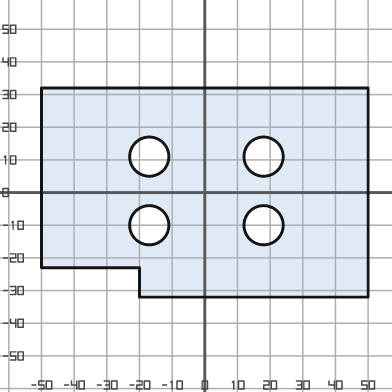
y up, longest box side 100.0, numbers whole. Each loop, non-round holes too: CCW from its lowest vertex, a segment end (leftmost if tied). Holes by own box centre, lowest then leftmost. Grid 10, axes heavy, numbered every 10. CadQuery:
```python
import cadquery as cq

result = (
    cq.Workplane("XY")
    .moveTo(-20.0, -32.0)
    .lineTo(50.0, -32.0)
    .lineTo(50.0, 32.0)
    .lineTo(-50.0, 32.0)
    .lineTo(-50.0, -23.0)
    .lineTo(-20.0, -23.0)
    .close()
    .moveTo(-17.0, -10.0)
    .circle(6.0)
    .moveTo(18.0, -10.0)
    .circle(6.0)
    .moveTo(-17.0, 11.0)
    .circle(6.0)
    .moveTo(18.0, 11.0)
    .circle(6.0)
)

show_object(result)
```